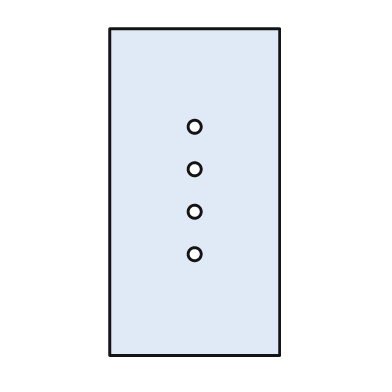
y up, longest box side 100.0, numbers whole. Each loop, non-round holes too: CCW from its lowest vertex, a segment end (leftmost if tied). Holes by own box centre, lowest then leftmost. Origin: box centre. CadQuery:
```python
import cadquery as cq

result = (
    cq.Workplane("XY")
    .moveTo(-26.0, -50.0)
    .lineTo(26.0, -50.0)
    .lineTo(26.0, 50.0)
    .lineTo(-26.0, 50.0)
    .close()
    .moveTo(0.0, -19.0)
    .circle(2.0)
    .moveTo(0.0, -6.0)
    .circle(2.0)
    .moveTo(0.0, 7.0)
    .circle(2.0)
    .moveTo(0.0, 20.0)
    .circle(2.0)
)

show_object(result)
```